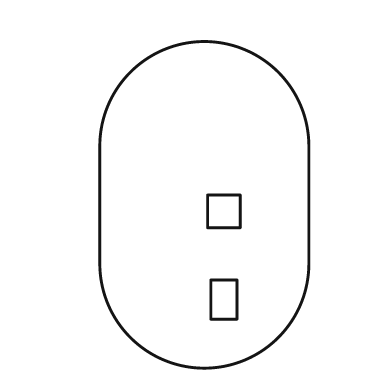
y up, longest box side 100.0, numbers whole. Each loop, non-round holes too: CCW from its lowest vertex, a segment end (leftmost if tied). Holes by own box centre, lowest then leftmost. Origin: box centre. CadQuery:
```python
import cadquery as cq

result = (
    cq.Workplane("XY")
    .moveTo(-32.0, -18.0)
    .threePointArc((0.0, -50.0), (32.0, -18.0))
    .lineTo(32.0, 18.0)
    .threePointArc((0.0, 50.0), (-32.0, 18.0))
    .close()
    .moveTo(2.0, -35.0)
    .lineTo(10.0, -35.0)
    .lineTo(10.0, -23.0)
    .lineTo(2.0, -23.0)
    .close()
    .moveTo(1.0, -7.0)
    .lineTo(11.0, -7.0)
    .lineTo(11.0, 3.0)
    .lineTo(1.0, 3.0)
    .close()
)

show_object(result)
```